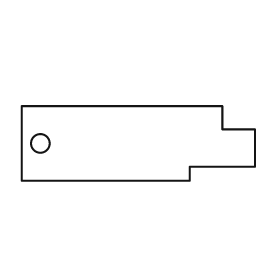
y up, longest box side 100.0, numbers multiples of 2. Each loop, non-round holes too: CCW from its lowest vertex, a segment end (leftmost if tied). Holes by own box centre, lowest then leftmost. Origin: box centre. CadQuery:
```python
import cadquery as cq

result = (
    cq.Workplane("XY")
    .moveTo(-50.0, -16.0)
    .lineTo(22.0, -16.0)
    .lineTo(22.0, -10.0)
    .lineTo(50.0, -10.0)
    .lineTo(50.0, 6.0)
    .lineTo(36.0, 6.0)
    .lineTo(36.0, 16.0)
    .lineTo(-50.0, 16.0)
    .close()
    .moveTo(-42.0, 0.0)
    .circle(4.0)
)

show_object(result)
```